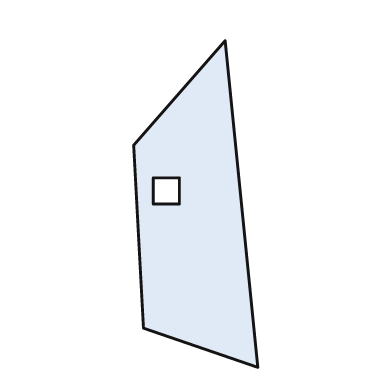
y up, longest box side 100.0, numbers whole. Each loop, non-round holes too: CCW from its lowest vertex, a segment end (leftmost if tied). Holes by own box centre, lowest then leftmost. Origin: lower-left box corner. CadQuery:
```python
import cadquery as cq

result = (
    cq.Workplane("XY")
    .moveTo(38.0, 0.0)
    .lineTo(28.0, 100.0)
    .lineTo(0.0, 68.0)
    .lineTo(3.0, 12.0)
    .close()
    .moveTo(6.0, 50.0)
    .lineTo(14.0, 50.0)
    .lineTo(14.0, 58.0)
    .lineTo(6.0, 58.0)
    .close()
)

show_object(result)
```